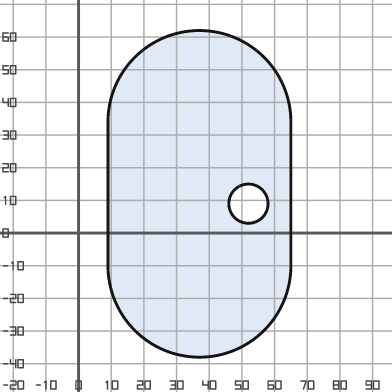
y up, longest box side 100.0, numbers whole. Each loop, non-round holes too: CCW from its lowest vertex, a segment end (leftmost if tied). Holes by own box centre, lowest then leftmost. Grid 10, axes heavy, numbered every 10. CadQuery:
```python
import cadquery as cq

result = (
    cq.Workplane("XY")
    .moveTo(9.0, -10.0)
    .threePointArc((37.0, -38.0), (65.0, -10.0))
    .lineTo(65.0, 34.0)
    .threePointArc((37.0, 62.0), (9.0, 34.0))
    .close()
    .moveTo(52.0, 9.0)
    .circle(6.0)
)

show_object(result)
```